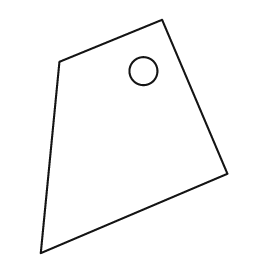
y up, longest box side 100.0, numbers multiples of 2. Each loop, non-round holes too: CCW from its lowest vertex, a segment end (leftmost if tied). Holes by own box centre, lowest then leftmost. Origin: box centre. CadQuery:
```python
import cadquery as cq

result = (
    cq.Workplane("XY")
    .moveTo(-40.0, -50.0)
    .lineTo(40.0, -16.0)
    .lineTo(12.0, 50.0)
    .lineTo(-32.0, 32.0)
    .close()
    .moveTo(4.0, 28.0)
    .circle(6.0)
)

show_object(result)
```